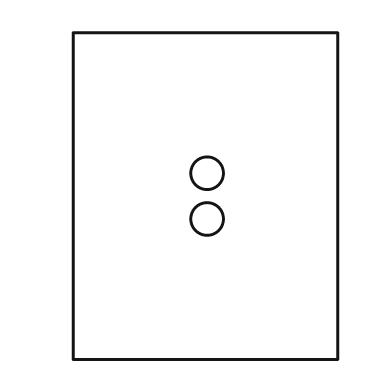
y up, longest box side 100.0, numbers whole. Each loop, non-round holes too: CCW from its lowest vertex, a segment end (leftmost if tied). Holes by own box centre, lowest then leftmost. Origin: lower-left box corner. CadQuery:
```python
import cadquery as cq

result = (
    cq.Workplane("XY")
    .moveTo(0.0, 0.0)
    .lineTo(81.0, 0.0)
    .lineTo(81.0, 100.0)
    .lineTo(0.0, 100.0)
    .close()
    .moveTo(41.0, 43.0)
    .circle(5.0)
    .moveTo(41.0, 57.0)
    .circle(5.0)
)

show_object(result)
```